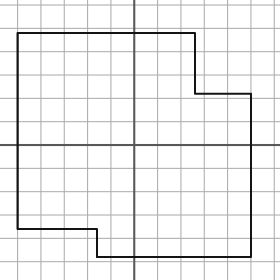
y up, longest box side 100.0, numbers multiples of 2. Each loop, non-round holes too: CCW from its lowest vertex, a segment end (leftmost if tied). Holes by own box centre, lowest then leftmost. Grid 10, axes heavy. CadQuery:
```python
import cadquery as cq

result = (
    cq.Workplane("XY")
    .moveTo(-16.0, -48.0)
    .lineTo(50.0, -48.0)
    .lineTo(50.0, 22.0)
    .lineTo(26.0, 22.0)
    .lineTo(26.0, 48.0)
    .lineTo(-50.0, 48.0)
    .lineTo(-50.0, -36.0)
    .lineTo(-16.0, -36.0)
    .close()
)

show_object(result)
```